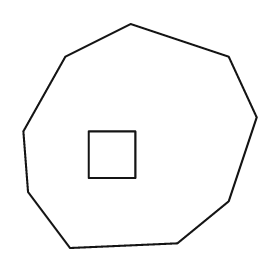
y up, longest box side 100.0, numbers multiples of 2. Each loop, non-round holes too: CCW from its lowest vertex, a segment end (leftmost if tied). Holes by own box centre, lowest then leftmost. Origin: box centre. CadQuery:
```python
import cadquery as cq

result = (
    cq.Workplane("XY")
    .moveTo(-30.0, -48.0)
    .lineTo(16.0, -46.0)
    .lineTo(38.0, -28.0)
    .lineTo(50.0, 8.0)
    .lineTo(38.0, 34.0)
    .lineTo(-4.0, 48.0)
    .lineTo(-32.0, 34.0)
    .lineTo(-50.0, 2.0)
    .lineTo(-48.0, -24.0)
    .close()
    .moveTo(-22.0, -18.0)
    .lineTo(-2.0, -18.0)
    .lineTo(-2.0, 2.0)
    .lineTo(-22.0, 2.0)
    .close()
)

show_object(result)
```